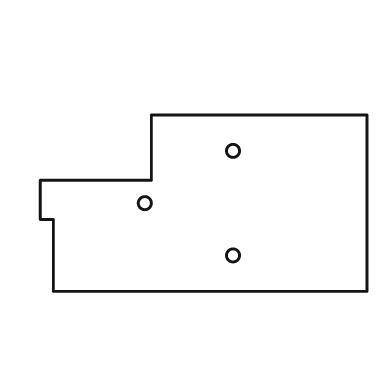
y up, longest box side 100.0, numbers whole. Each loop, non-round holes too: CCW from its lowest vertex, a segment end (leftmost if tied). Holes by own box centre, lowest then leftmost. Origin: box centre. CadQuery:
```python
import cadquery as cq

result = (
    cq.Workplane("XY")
    .moveTo(-46.0, -27.0)
    .lineTo(50.0, -27.0)
    .lineTo(50.0, 27.0)
    .lineTo(-16.0, 27.0)
    .lineTo(-16.0, 7.0)
    .lineTo(-50.0, 7.0)
    .lineTo(-50.0, -5.0)
    .lineTo(-46.0, -5.0)
    .close()
    .moveTo(9.0, -16.0)
    .circle(2.0)
    .moveTo(-18.0, 0.0)
    .circle(2.0)
    .moveTo(9.0, 16.0)
    .circle(2.0)
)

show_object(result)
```